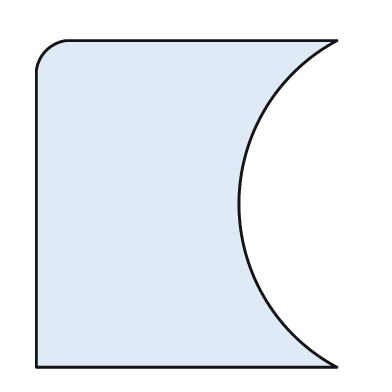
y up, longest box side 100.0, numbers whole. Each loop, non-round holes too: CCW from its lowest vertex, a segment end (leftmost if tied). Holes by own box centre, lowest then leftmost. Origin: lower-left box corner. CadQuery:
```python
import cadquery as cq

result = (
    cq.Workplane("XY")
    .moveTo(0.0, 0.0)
    .lineTo(92.0, 0.0)
    .threePointArc((62.0, 50.0), (92.0, 100.0))
    .lineTo(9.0, 100.0)
    .threePointArc((3.0, 97.0), (0.0, 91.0))
    .close()
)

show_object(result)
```